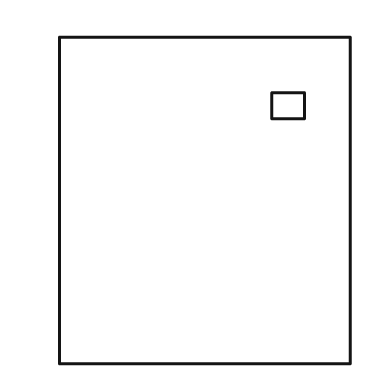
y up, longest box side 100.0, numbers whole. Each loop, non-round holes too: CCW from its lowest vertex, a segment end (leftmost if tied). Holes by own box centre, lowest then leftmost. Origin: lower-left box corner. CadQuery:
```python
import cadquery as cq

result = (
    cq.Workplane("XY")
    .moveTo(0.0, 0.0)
    .lineTo(89.0, 0.0)
    .lineTo(89.0, 100.0)
    .lineTo(0.0, 100.0)
    .close()
    .moveTo(65.0, 75.0)
    .lineTo(75.0, 75.0)
    .lineTo(75.0, 83.0)
    .lineTo(65.0, 83.0)
    .close()
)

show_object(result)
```